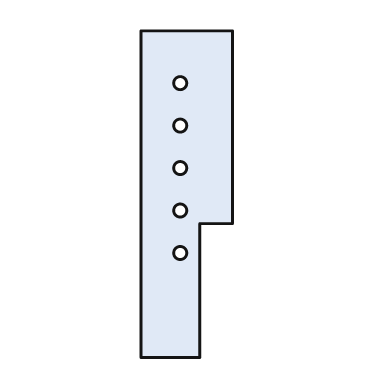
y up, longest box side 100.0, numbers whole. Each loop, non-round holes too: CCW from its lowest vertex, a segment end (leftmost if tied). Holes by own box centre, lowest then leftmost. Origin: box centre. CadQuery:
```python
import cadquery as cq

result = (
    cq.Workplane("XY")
    .moveTo(-14.0, -50.0)
    .lineTo(4.0, -50.0)
    .lineTo(4.0, -9.0)
    .lineTo(14.0, -9.0)
    .lineTo(14.0, 50.0)
    .lineTo(-14.0, 50.0)
    .close()
    .moveTo(-2.0, -18.0)
    .circle(2.0)
    .moveTo(-2.0, -5.0)
    .circle(2.0)
    .moveTo(-2.0, 8.0)
    .circle(2.0)
    .moveTo(-2.0, 21.0)
    .circle(2.0)
    .moveTo(-2.0, 34.0)
    .circle(2.0)
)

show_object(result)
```